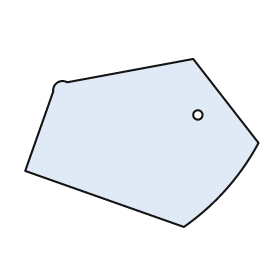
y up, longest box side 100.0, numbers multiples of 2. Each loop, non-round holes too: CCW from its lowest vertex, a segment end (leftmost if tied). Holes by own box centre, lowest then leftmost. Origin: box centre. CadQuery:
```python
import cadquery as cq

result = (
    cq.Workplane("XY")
    .moveTo(18.0, -36.0)
    .threePointArc((36.0, -20.0), (50.0, 0.0))
    .lineTo(22.0, 36.0)
    .lineTo(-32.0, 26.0)
    .threePointArc((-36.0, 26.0), (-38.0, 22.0))
    .lineTo(-50.0, -12.0)
    .close()
    .moveTo(24.0, 12.0)
    .circle(2.0)
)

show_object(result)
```